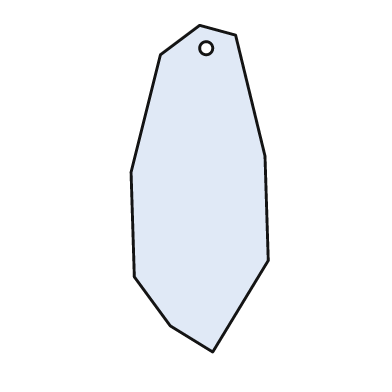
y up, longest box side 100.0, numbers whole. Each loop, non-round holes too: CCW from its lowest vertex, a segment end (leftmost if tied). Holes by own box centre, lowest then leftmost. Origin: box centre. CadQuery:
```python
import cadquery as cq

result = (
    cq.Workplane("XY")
    .moveTo(4.0, -50.0)
    .lineTo(21.0, -22.0)
    .lineTo(20.0, 10.0)
    .lineTo(11.0, 47.0)
    .lineTo(0.0, 50.0)
    .lineTo(-12.0, 41.0)
    .lineTo(-21.0, 5.0)
    .lineTo(-20.0, -27.0)
    .lineTo(-9.0, -42.0)
    .close()
    .moveTo(2.0, 43.0)
    .circle(2.0)
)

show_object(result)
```